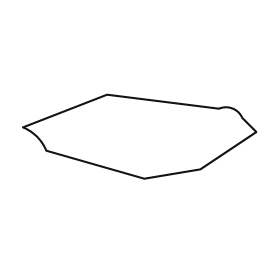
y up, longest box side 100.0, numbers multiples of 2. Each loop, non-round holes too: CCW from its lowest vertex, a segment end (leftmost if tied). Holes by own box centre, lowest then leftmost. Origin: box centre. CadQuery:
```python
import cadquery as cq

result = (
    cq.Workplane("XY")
    .moveTo(2.0, -18.0)
    .lineTo(26.0, -14.0)
    .lineTo(50.0, 2.0)
    .lineTo(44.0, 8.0)
    .threePointArc((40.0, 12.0), (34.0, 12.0))
    .lineTo(-14.0, 18.0)
    .lineTo(-50.0, 4.0)
    .threePointArc((-44.0, 0.0), (-40.0, -6.0))
    .close()
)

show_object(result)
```